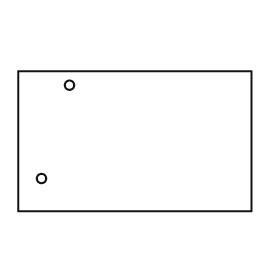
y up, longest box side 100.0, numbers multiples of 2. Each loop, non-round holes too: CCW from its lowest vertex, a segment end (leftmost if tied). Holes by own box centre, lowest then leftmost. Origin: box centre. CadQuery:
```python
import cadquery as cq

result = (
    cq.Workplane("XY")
    .moveTo(-50.0, -30.0)
    .lineTo(50.0, -30.0)
    .lineTo(50.0, 30.0)
    .lineTo(-50.0, 30.0)
    .close()
    .moveTo(-40.0, -16.0)
    .circle(2.0)
    .moveTo(-28.0, 24.0)
    .circle(2.0)
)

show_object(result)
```